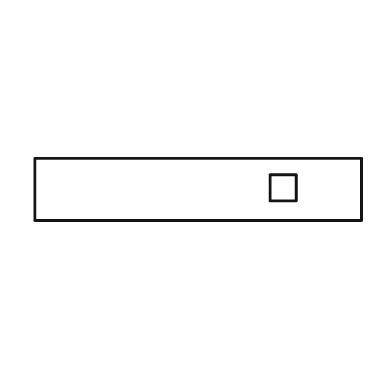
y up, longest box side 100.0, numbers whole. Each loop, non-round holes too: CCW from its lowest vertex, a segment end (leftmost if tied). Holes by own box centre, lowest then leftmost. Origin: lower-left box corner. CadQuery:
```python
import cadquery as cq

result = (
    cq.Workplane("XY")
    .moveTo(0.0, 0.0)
    .lineTo(100.0, 0.0)
    .lineTo(100.0, 19.0)
    .lineTo(0.0, 19.0)
    .close()
    .moveTo(72.0, 6.0)
    .lineTo(80.0, 6.0)
    .lineTo(80.0, 14.0)
    .lineTo(72.0, 14.0)
    .close()
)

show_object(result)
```